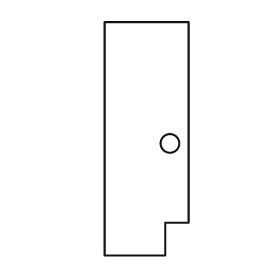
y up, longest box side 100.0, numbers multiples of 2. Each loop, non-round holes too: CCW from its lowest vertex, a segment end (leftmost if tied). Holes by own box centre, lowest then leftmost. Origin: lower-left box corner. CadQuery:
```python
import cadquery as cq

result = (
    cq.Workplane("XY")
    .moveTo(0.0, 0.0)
    .lineTo(26.0, 0.0)
    .lineTo(26.0, 14.0)
    .lineTo(36.0, 14.0)
    .lineTo(36.0, 100.0)
    .lineTo(0.0, 100.0)
    .close()
    .moveTo(28.0, 48.0)
    .circle(4.0)
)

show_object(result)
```